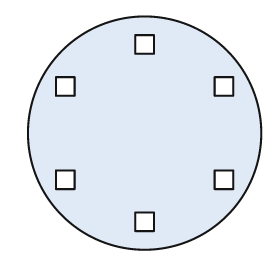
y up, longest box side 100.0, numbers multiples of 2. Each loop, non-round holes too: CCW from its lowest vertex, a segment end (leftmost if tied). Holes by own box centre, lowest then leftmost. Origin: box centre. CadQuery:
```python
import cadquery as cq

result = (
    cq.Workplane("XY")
    .moveTo(0.0, 0.0)
    .circle(50.0)
    .moveTo(-4.0, -42.0)
    .lineTo(4.0, -42.0)
    .lineTo(4.0, -34.0)
    .lineTo(-4.0, -34.0)
    .close()
    .moveTo(-38.0, -24.0)
    .lineTo(-30.0, -24.0)
    .lineTo(-30.0, -16.0)
    .lineTo(-38.0, -16.0)
    .close()
    .moveTo(30.0, -24.0)
    .lineTo(38.0, -24.0)
    .lineTo(38.0, -16.0)
    .lineTo(30.0, -16.0)
    .close()
    .moveTo(-38.0, 16.0)
    .lineTo(-30.0, 16.0)
    .lineTo(-30.0, 24.0)
    .lineTo(-38.0, 24.0)
    .close()
    .moveTo(30.0, 16.0)
    .lineTo(38.0, 16.0)
    .lineTo(38.0, 24.0)
    .lineTo(30.0, 24.0)
    .close()
    .moveTo(-4.0, 34.0)
    .lineTo(4.0, 34.0)
    .lineTo(4.0, 42.0)
    .lineTo(-4.0, 42.0)
    .close()
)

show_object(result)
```